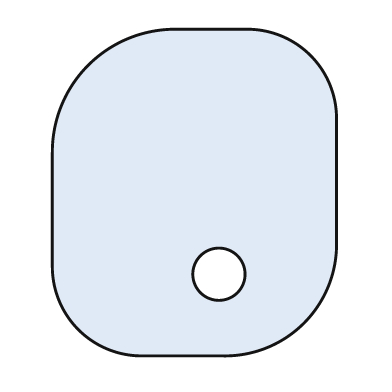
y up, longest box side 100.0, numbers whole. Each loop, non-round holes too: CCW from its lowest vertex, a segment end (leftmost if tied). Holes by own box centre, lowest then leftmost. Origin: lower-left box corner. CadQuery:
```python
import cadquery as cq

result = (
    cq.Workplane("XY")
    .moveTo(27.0, 0.0)
    .lineTo(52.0, 0.0)
    .threePointArc((77.0, 10.0), (87.0, 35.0))
    .lineTo(87.0, 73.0)
    .threePointArc((79.0, 92.0), (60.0, 100.0))
    .lineTo(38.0, 100.0)
    .threePointArc((11.0, 89.0), (0.0, 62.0))
    .lineTo(0.0, 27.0)
    .threePointArc((8.0, 8.0), (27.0, 0.0))
    .close()
    .moveTo(51.0, 25.0)
    .circle(8.0)
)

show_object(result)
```